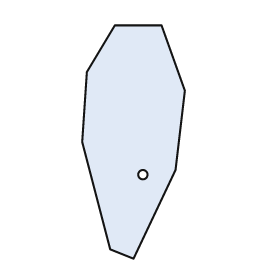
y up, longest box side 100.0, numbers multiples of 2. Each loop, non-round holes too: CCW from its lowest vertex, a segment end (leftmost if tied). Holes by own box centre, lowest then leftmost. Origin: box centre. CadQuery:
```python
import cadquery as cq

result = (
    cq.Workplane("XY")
    .moveTo(0.0, -50.0)
    .lineTo(18.0, -12.0)
    .lineTo(22.0, 22.0)
    .lineTo(12.0, 50.0)
    .lineTo(-8.0, 50.0)
    .lineTo(-20.0, 30.0)
    .lineTo(-22.0, 0.0)
    .lineTo(-10.0, -46.0)
    .close()
    .moveTo(4.0, -14.0)
    .circle(2.0)
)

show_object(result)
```